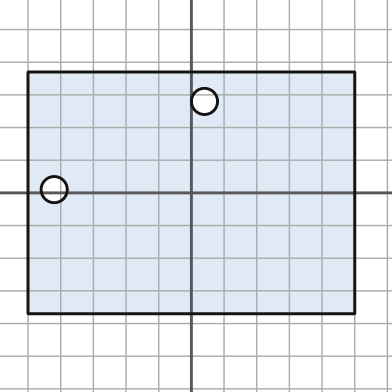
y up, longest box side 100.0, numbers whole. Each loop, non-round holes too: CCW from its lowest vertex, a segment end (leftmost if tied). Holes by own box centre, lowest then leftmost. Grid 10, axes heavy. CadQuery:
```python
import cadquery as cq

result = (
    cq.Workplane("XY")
    .moveTo(-50.0, -37.0)
    .lineTo(50.0, -37.0)
    .lineTo(50.0, 37.0)
    .lineTo(-50.0, 37.0)
    .close()
    .moveTo(-42.0, 1.0)
    .circle(4.0)
    .moveTo(4.0, 28.0)
    .circle(4.0)
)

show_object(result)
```